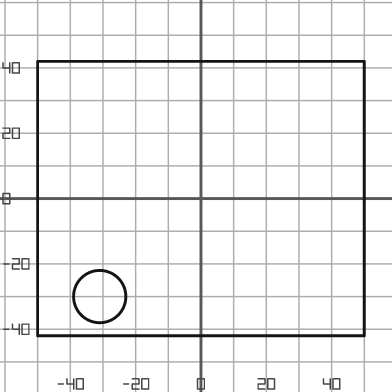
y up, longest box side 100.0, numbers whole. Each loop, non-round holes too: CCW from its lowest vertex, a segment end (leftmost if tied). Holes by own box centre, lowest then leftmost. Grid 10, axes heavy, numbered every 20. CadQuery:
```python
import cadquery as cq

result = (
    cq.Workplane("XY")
    .moveTo(-50.0, -42.0)
    .lineTo(50.0, -42.0)
    .lineTo(50.0, 42.0)
    .lineTo(-50.0, 42.0)
    .close()
    .moveTo(-31.0, -30.0)
    .circle(8.0)
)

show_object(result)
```